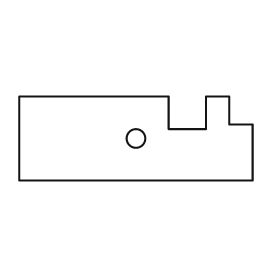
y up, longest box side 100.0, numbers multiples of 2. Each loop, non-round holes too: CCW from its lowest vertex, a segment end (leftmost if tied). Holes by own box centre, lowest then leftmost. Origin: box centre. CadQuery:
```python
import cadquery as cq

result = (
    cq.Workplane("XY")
    .moveTo(-50.0, -18.0)
    .lineTo(50.0, -18.0)
    .lineTo(50.0, 6.0)
    .lineTo(40.0, 6.0)
    .lineTo(40.0, 18.0)
    .lineTo(30.0, 18.0)
    .lineTo(30.0, 4.0)
    .lineTo(14.0, 4.0)
    .lineTo(14.0, 18.0)
    .lineTo(-50.0, 18.0)
    .close()
    .moveTo(0.0, 0.0)
    .circle(4.0)
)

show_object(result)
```